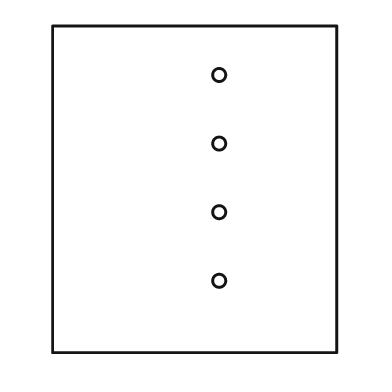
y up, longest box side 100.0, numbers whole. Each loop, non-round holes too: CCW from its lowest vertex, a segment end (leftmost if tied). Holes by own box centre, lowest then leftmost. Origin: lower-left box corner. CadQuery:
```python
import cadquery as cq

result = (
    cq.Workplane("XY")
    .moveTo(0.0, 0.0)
    .lineTo(87.0, 0.0)
    .lineTo(87.0, 100.0)
    .lineTo(0.0, 100.0)
    .close()
    .moveTo(51.0, 22.0)
    .circle(2.0)
    .moveTo(51.0, 43.0)
    .circle(2.0)
    .moveTo(51.0, 64.0)
    .circle(2.0)
    .moveTo(51.0, 85.0)
    .circle(2.0)
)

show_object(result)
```